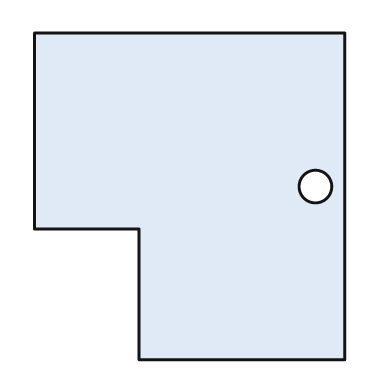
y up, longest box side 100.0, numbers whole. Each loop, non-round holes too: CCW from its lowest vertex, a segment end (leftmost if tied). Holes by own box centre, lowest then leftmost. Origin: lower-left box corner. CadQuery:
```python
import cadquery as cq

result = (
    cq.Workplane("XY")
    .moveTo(32.0, 0.0)
    .lineTo(95.0, 0.0)
    .lineTo(95.0, 100.0)
    .lineTo(0.0, 100.0)
    .lineTo(0.0, 40.0)
    .lineTo(32.0, 40.0)
    .close()
    .moveTo(86.0, 53.0)
    .circle(5.0)
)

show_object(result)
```